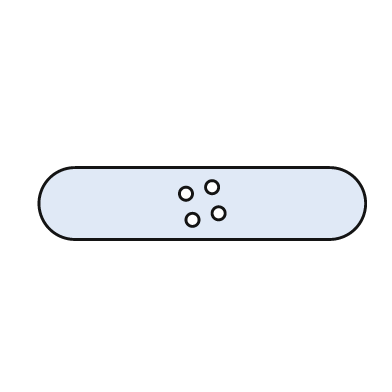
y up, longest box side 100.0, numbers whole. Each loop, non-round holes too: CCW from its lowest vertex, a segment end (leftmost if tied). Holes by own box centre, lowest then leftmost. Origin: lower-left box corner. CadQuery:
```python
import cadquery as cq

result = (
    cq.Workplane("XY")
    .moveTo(11.0, 0.0)
    .lineTo(89.0, 0.0)
    .threePointArc((100.0, 11.0), (89.0, 22.0))
    .lineTo(11.0, 22.0)
    .threePointArc((0.0, 11.0), (11.0, 0.0))
    .close()
    .moveTo(47.0, 6.0)
    .circle(2.0)
    .moveTo(55.0, 8.0)
    .circle(2.0)
    .moveTo(45.0, 14.0)
    .circle(2.0)
    .moveTo(53.0, 16.0)
    .circle(2.0)
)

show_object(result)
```